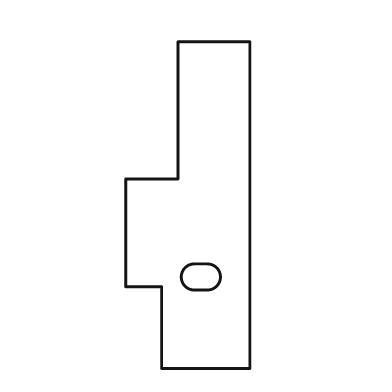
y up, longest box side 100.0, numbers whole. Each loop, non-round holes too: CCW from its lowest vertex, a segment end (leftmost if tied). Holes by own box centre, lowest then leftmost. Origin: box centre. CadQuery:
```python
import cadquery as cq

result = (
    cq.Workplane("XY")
    .moveTo(-8.0, -50.0)
    .lineTo(19.0, -50.0)
    .lineTo(19.0, 50.0)
    .lineTo(-3.0, 50.0)
    .lineTo(-3.0, 8.0)
    .lineTo(-19.0, 8.0)
    .lineTo(-19.0, -25.0)
    .lineTo(-8.0, -25.0)
    .close()
    .moveTo(2.0, -26.0)
    .lineTo(6.0, -26.0)
    .threePointArc((10.0, -22.0), (6.0, -18.0))
    .lineTo(2.0, -18.0)
    .threePointArc((-2.0, -22.0), (2.0, -26.0))
    .close()
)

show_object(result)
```